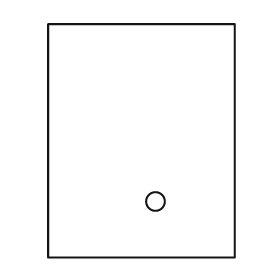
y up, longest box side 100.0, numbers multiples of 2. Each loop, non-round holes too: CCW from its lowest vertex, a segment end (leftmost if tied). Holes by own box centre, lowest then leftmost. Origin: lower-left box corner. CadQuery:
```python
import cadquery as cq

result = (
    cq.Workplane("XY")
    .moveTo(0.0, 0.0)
    .lineTo(80.0, 0.0)
    .lineTo(80.0, 100.0)
    .lineTo(0.0, 100.0)
    .close()
    .moveTo(46.0, 24.0)
    .circle(4.0)
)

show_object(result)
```